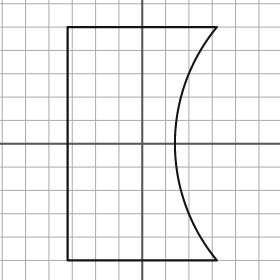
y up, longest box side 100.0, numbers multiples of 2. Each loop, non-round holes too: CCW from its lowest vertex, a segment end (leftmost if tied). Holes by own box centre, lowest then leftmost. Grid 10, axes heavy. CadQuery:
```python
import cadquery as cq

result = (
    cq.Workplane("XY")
    .moveTo(-32.0, -50.0)
    .lineTo(32.0, -50.0)
    .threePointArc((14.0, 0.0), (32.0, 50.0))
    .lineTo(-32.0, 50.0)
    .close()
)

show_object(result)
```